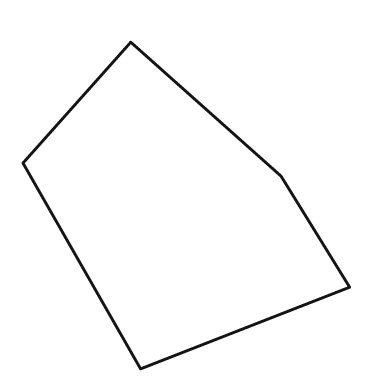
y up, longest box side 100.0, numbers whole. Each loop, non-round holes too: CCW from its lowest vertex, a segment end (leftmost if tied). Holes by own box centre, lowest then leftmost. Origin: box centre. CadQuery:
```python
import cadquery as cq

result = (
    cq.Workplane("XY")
    .moveTo(-14.0, -50.0)
    .lineTo(50.0, -25.0)
    .lineTo(29.0, 9.0)
    .lineTo(-17.0, 50.0)
    .lineTo(-50.0, 13.0)
    .close()
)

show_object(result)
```